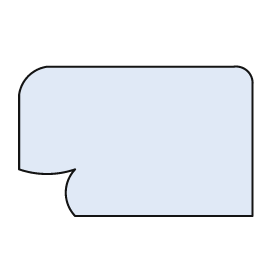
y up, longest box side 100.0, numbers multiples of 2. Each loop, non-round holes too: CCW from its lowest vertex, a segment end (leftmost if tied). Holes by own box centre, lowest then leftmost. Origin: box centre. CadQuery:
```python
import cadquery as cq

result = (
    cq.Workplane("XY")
    .moveTo(-26.0, -32.0)
    .lineTo(50.0, -32.0)
    .lineTo(50.0, 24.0)
    .threePointArc((48.0, 30.0), (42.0, 32.0))
    .lineTo(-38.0, 32.0)
    .threePointArc((-46.0, 28.0), (-50.0, 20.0))
    .lineTo(-50.0, -12.0)
    .threePointArc((-38.0, -14.0), (-26.0, -12.0))
    .threePointArc((-30.0, -22.0), (-26.0, -32.0))
    .close()
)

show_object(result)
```